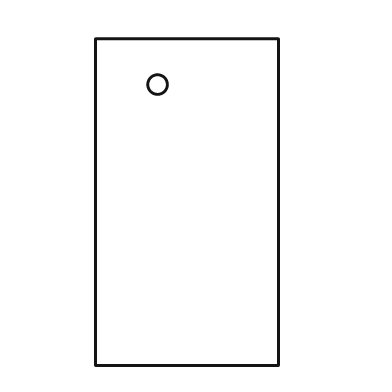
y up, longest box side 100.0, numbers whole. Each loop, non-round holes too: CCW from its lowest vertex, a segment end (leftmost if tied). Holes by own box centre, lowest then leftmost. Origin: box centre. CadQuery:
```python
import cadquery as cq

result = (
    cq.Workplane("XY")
    .moveTo(-28.0, -50.0)
    .lineTo(28.0, -50.0)
    .lineTo(28.0, 50.0)
    .lineTo(-28.0, 50.0)
    .close()
    .moveTo(-9.0, 36.0)
    .circle(3.0)
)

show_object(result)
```